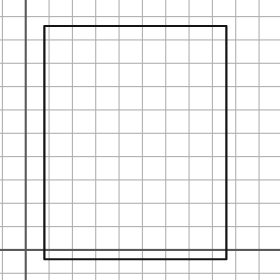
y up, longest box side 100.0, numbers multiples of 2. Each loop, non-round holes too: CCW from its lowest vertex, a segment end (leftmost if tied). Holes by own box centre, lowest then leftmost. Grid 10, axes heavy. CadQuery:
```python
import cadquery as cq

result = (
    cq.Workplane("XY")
    .moveTo(8.0, -4.0)
    .lineTo(86.0, -4.0)
    .lineTo(86.0, 96.0)
    .lineTo(8.0, 96.0)
    .close()
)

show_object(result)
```